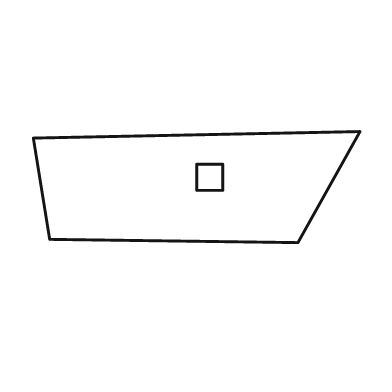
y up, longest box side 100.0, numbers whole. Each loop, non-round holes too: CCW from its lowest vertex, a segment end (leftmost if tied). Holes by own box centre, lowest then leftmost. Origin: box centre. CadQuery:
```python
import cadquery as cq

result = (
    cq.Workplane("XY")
    .moveTo(31.0, -17.0)
    .lineTo(50.0, 17.0)
    .lineTo(-50.0, 15.0)
    .lineTo(-45.0, -16.0)
    .close()
    .moveTo(0.0, -1.0)
    .lineTo(8.0, -1.0)
    .lineTo(8.0, 7.0)
    .lineTo(0.0, 7.0)
    .close()
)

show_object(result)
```